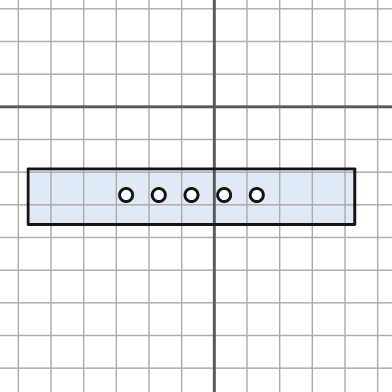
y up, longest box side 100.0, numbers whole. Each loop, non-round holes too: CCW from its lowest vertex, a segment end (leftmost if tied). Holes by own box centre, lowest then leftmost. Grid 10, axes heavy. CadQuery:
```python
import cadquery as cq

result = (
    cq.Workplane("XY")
    .moveTo(-57.0, -36.0)
    .lineTo(43.0, -36.0)
    .lineTo(43.0, -19.0)
    .lineTo(-57.0, -19.0)
    .close()
    .moveTo(-27.0, -27.0)
    .circle(2.0)
    .moveTo(-17.0, -27.0)
    .circle(2.0)
    .moveTo(-7.0, -27.0)
    .circle(2.0)
    .moveTo(3.0, -27.0)
    .circle(2.0)
    .moveTo(13.0, -27.0)
    .circle(2.0)
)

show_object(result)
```